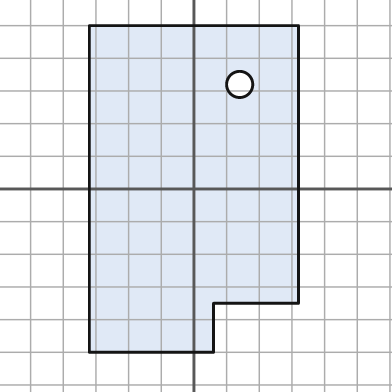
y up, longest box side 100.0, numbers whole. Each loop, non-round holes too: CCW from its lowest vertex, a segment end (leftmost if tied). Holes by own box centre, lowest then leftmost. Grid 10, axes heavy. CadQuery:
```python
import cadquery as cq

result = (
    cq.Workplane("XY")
    .moveTo(-32.0, -50.0)
    .lineTo(6.0, -50.0)
    .lineTo(6.0, -35.0)
    .lineTo(32.0, -35.0)
    .lineTo(32.0, 50.0)
    .lineTo(-32.0, 50.0)
    .close()
    .moveTo(14.0, 32.0)
    .circle(4.0)
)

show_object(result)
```